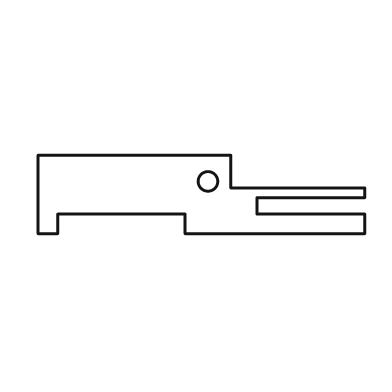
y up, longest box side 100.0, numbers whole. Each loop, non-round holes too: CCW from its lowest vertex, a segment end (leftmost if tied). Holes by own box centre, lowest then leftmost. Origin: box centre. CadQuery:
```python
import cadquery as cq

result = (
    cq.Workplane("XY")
    .moveTo(-50.0, -12.0)
    .lineTo(-44.0, -12.0)
    .lineTo(-44.0, -6.0)
    .lineTo(-5.0, -6.0)
    .lineTo(-5.0, -12.0)
    .lineTo(50.0, -12.0)
    .lineTo(50.0, -6.0)
    .lineTo(17.0, -6.0)
    .lineTo(17.0, -1.0)
    .lineTo(50.0, -1.0)
    .lineTo(50.0, 2.0)
    .lineTo(9.0, 2.0)
    .lineTo(9.0, 12.0)
    .lineTo(-50.0, 12.0)
    .close()
    .moveTo(2.0, 4.0)
    .circle(3.0)
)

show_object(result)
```